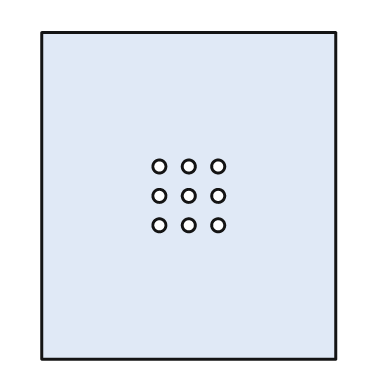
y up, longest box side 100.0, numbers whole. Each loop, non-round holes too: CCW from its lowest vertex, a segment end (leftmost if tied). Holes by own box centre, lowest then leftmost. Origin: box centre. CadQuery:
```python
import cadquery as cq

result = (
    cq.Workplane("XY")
    .moveTo(-45.0, -50.0)
    .lineTo(45.0, -50.0)
    .lineTo(45.0, 50.0)
    .lineTo(-45.0, 50.0)
    .close()
    .moveTo(-9.0, -9.0)
    .circle(2.0)
    .moveTo(0.0, -9.0)
    .circle(2.0)
    .moveTo(9.0, -9.0)
    .circle(2.0)
    .moveTo(-9.0, 0.0)
    .circle(2.0)
    .moveTo(0.0, 0.0)
    .circle(2.0)
    .moveTo(9.0, 0.0)
    .circle(2.0)
    .moveTo(-9.0, 9.0)
    .circle(2.0)
    .moveTo(0.0, 9.0)
    .circle(2.0)
    .moveTo(9.0, 9.0)
    .circle(2.0)
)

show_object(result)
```